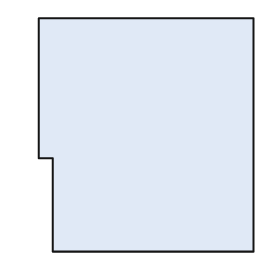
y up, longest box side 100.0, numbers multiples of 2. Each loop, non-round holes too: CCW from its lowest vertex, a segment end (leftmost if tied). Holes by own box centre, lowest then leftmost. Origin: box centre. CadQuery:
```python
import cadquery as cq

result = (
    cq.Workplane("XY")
    .moveTo(-40.0, -50.0)
    .lineTo(46.0, -50.0)
    .lineTo(46.0, 50.0)
    .lineTo(-46.0, 50.0)
    .lineTo(-46.0, -10.0)
    .lineTo(-40.0, -10.0)
    .close()
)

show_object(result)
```